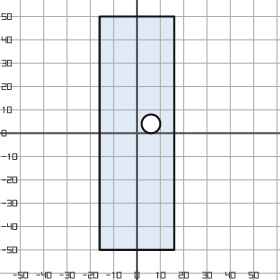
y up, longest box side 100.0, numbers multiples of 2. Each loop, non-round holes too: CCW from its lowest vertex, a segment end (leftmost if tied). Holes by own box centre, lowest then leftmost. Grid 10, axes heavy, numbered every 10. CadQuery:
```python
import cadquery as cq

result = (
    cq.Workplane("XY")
    .moveTo(-16.0, -50.0)
    .lineTo(16.0, -50.0)
    .lineTo(16.0, 50.0)
    .lineTo(-16.0, 50.0)
    .close()
    .moveTo(6.0, 4.0)
    .circle(4.0)
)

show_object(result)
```